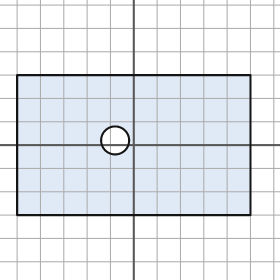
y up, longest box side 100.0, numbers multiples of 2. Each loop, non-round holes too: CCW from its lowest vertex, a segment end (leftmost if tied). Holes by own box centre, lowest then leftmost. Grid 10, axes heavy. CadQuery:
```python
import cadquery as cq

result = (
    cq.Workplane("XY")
    .moveTo(-50.0, -30.0)
    .lineTo(50.0, -30.0)
    .lineTo(50.0, 30.0)
    .lineTo(-50.0, 30.0)
    .close()
    .moveTo(-8.0, 2.0)
    .circle(6.0)
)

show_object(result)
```